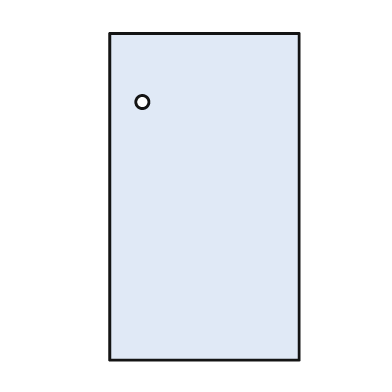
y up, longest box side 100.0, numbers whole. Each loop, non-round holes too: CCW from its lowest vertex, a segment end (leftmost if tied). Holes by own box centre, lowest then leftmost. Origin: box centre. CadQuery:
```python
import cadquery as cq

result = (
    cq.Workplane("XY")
    .moveTo(-29.0, -50.0)
    .lineTo(29.0, -50.0)
    .lineTo(29.0, 50.0)
    .lineTo(-29.0, 50.0)
    .close()
    .moveTo(-19.0, 29.0)
    .circle(2.0)
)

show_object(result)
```